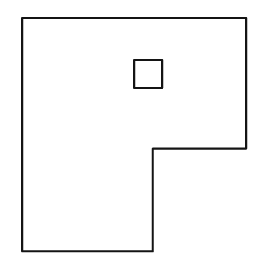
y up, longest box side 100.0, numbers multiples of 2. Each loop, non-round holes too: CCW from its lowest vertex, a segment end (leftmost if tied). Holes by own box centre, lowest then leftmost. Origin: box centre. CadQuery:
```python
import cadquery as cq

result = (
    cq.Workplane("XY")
    .moveTo(-48.0, -50.0)
    .lineTo(8.0, -50.0)
    .lineTo(8.0, -6.0)
    .lineTo(48.0, -6.0)
    .lineTo(48.0, 50.0)
    .lineTo(-48.0, 50.0)
    .close()
    .moveTo(0.0, 20.0)
    .lineTo(12.0, 20.0)
    .lineTo(12.0, 32.0)
    .lineTo(0.0, 32.0)
    .close()
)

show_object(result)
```